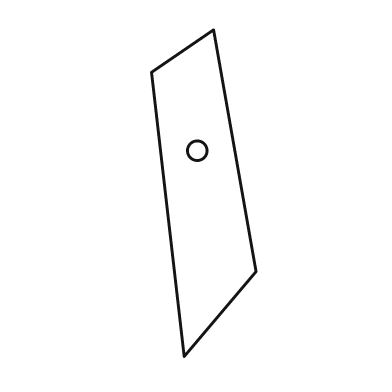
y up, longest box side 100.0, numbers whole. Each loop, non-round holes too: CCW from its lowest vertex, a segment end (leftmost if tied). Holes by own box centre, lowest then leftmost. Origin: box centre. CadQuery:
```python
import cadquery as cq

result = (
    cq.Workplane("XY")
    .moveTo(-6.0, -50.0)
    .lineTo(16.0, -24.0)
    .lineTo(3.0, 50.0)
    .lineTo(-16.0, 37.0)
    .close()
    .moveTo(-2.0, 13.0)
    .circle(3.0)
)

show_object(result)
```